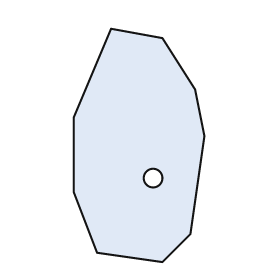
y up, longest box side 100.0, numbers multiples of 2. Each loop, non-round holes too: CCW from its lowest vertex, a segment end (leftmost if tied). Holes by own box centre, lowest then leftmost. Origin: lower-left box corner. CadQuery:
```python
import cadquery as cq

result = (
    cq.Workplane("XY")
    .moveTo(38.0, 0.0)
    .lineTo(50.0, 12.0)
    .lineTo(56.0, 54.0)
    .lineTo(52.0, 74.0)
    .lineTo(38.0, 96.0)
    .lineTo(16.0, 100.0)
    .lineTo(0.0, 62.0)
    .lineTo(0.0, 30.0)
    .lineTo(10.0, 4.0)
    .close()
    .moveTo(34.0, 36.0)
    .circle(4.0)
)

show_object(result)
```